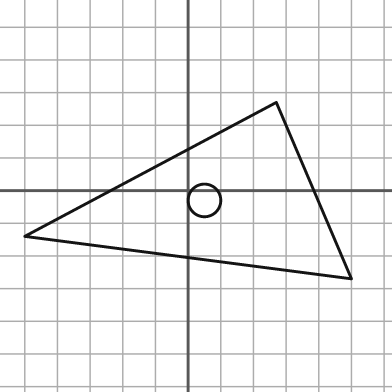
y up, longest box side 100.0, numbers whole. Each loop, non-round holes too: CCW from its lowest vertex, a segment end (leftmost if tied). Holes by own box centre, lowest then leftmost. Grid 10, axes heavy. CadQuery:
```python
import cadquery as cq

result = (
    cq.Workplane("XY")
    .moveTo(50.0, -27.0)
    .lineTo(27.0, 27.0)
    .lineTo(-50.0, -14.0)
    .close()
    .moveTo(5.0, -3.0)
    .circle(5.0)
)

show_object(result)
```